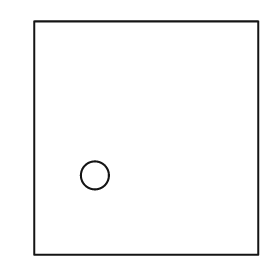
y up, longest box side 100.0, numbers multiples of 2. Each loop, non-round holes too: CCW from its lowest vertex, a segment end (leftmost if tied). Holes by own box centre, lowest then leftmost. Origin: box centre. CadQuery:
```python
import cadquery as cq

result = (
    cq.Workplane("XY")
    .moveTo(-48.0, -50.0)
    .lineTo(48.0, -50.0)
    .lineTo(48.0, 50.0)
    .lineTo(-48.0, 50.0)
    .close()
    .moveTo(-22.0, -16.0)
    .circle(6.0)
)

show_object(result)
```